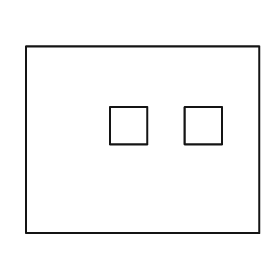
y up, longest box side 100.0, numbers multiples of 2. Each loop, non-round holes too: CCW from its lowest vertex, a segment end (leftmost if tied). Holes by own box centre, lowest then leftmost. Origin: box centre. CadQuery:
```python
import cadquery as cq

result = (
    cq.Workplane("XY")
    .moveTo(-50.0, -40.0)
    .lineTo(50.0, -40.0)
    .lineTo(50.0, 40.0)
    .lineTo(-50.0, 40.0)
    .close()
    .moveTo(-14.0, -2.0)
    .lineTo(2.0, -2.0)
    .lineTo(2.0, 14.0)
    .lineTo(-14.0, 14.0)
    .close()
    .moveTo(18.0, -2.0)
    .lineTo(34.0, -2.0)
    .lineTo(34.0, 14.0)
    .lineTo(18.0, 14.0)
    .close()
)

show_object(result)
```